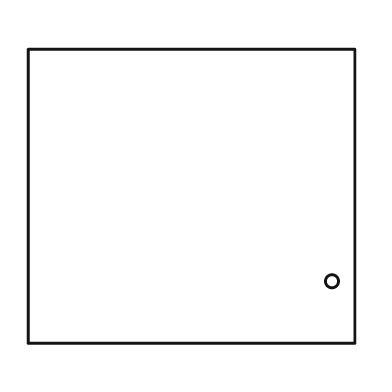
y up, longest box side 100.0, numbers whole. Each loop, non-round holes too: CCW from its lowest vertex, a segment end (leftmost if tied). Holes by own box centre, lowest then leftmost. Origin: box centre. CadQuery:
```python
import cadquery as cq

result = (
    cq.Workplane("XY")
    .moveTo(-50.0, -45.0)
    .lineTo(50.0, -45.0)
    .lineTo(50.0, 45.0)
    .lineTo(-50.0, 45.0)
    .close()
    .moveTo(43.0, -26.0)
    .circle(2.0)
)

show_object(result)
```